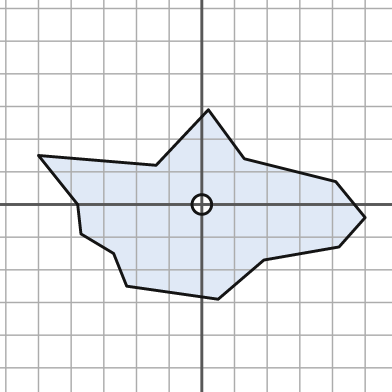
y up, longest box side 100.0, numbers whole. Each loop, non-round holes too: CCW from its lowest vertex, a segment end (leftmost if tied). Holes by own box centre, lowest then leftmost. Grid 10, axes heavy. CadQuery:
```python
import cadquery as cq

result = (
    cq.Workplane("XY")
    .moveTo(5.0, -29.0)
    .lineTo(19.0, -17.0)
    .lineTo(42.0, -13.0)
    .lineTo(50.0, -4.0)
    .lineTo(41.0, 7.0)
    .lineTo(13.0, 14.0)
    .lineTo(2.0, 29.0)
    .lineTo(-14.0, 12.0)
    .lineTo(-50.0, 15.0)
    .lineTo(-38.0, 0.0)
    .lineTo(-37.0, -9.0)
    .lineTo(-27.0, -15.0)
    .lineTo(-23.0, -25.0)
    .close()
    .moveTo(0.0, 0.0)
    .circle(3.0)
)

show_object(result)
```